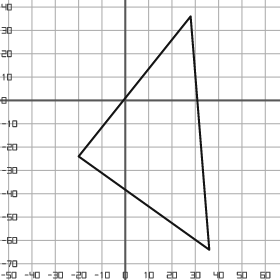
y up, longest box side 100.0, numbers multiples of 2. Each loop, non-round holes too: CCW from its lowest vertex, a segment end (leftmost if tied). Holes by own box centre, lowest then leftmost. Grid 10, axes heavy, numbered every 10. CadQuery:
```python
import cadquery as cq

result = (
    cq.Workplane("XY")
    .moveTo(36.0, -64.0)
    .lineTo(28.0, 36.0)
    .lineTo(-20.0, -24.0)
    .close()
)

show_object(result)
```